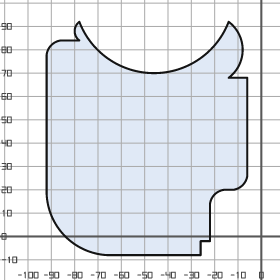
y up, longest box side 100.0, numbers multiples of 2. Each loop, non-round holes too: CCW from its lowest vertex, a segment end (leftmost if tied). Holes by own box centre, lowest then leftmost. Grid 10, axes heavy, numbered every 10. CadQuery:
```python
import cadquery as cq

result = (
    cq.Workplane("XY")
    .moveTo(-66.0, -8.0)
    .lineTo(-26.0, -8.0)
    .lineTo(-26.0, -2.0)
    .lineTo(-22.0, -2.0)
    .lineTo(-22.0, 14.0)
    .threePointArc((-20.0, 18.0), (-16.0, 20.0))
    .lineTo(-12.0, 20.0)
    .threePointArc((-8.0, 22.0), (-6.0, 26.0))
    .lineTo(-6.0, 68.0)
    .lineTo(-14.0, 68.0)
    .threePointArc((-8.0, 80.0), (-14.0, 92.0))
    .threePointArc((-46.0, 70.0), (-78.0, 92.0))
    .threePointArc((-80.0, 88.0), (-78.0, 84.0))
    .lineTo(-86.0, 84.0)
    .threePointArc((-90.0, 82.0), (-92.0, 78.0))
    .lineTo(-92.0, 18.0)
    .threePointArc((-84.0, 0.0), (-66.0, -8.0))
    .close()
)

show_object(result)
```